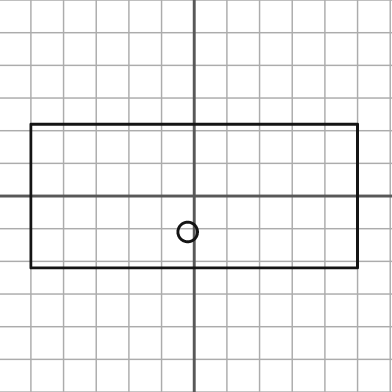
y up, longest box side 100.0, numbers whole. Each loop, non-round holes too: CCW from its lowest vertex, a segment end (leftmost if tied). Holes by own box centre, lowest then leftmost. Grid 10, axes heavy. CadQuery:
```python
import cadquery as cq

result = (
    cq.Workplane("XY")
    .moveTo(-50.0, -22.0)
    .lineTo(50.0, -22.0)
    .lineTo(50.0, 22.0)
    .lineTo(-50.0, 22.0)
    .close()
    .moveTo(-2.0, -11.0)
    .circle(3.0)
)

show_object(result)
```